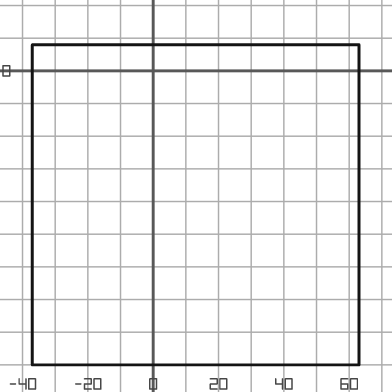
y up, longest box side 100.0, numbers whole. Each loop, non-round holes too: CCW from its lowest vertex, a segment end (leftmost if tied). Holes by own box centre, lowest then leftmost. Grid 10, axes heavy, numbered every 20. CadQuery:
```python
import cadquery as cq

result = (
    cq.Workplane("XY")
    .moveTo(-37.0, -90.0)
    .lineTo(63.0, -90.0)
    .lineTo(63.0, 8.0)
    .lineTo(-37.0, 8.0)
    .close()
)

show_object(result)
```